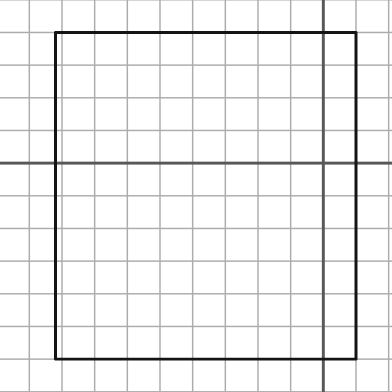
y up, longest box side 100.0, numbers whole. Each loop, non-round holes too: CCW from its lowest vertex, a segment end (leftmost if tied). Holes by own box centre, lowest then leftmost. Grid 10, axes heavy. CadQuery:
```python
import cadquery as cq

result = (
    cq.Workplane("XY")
    .moveTo(-82.0, -60.0)
    .lineTo(10.0, -60.0)
    .lineTo(10.0, 40.0)
    .lineTo(-82.0, 40.0)
    .close()
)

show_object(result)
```